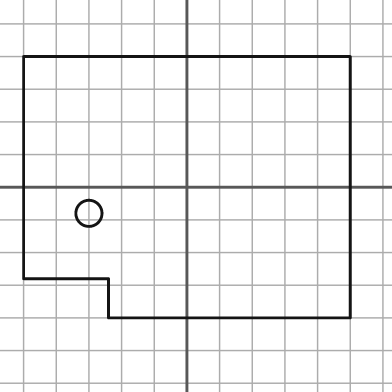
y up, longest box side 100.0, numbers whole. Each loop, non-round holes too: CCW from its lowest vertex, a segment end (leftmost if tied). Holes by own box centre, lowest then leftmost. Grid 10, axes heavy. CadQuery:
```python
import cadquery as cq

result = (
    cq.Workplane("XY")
    .moveTo(-24.0, -40.0)
    .lineTo(50.0, -40.0)
    .lineTo(50.0, 40.0)
    .lineTo(-50.0, 40.0)
    .lineTo(-50.0, -28.0)
    .lineTo(-24.0, -28.0)
    .close()
    .moveTo(-30.0, -8.0)
    .circle(4.0)
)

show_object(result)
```